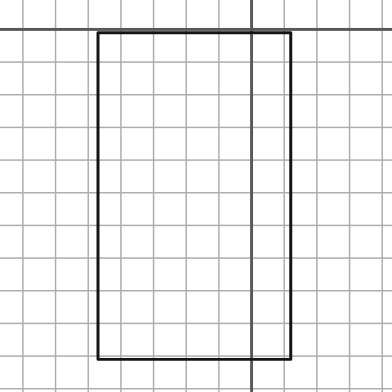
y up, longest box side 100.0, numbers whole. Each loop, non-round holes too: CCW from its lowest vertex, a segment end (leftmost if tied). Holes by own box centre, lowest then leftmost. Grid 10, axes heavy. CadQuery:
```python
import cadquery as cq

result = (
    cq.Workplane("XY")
    .moveTo(-47.0, -101.0)
    .lineTo(12.0, -101.0)
    .lineTo(12.0, -1.0)
    .lineTo(-47.0, -1.0)
    .close()
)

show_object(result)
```